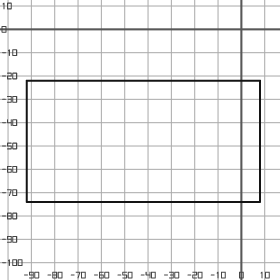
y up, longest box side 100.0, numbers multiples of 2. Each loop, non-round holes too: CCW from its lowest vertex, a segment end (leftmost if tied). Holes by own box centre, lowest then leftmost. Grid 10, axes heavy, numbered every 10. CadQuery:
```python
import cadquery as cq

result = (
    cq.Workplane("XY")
    .moveTo(-92.0, -74.0)
    .lineTo(8.0, -74.0)
    .lineTo(8.0, -22.0)
    .lineTo(-92.0, -22.0)
    .close()
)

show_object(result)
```